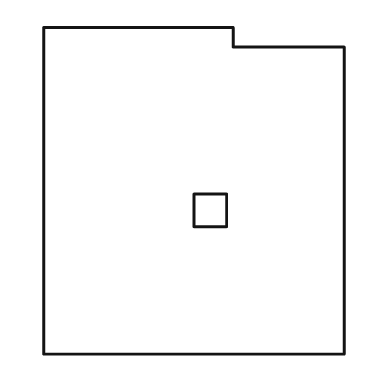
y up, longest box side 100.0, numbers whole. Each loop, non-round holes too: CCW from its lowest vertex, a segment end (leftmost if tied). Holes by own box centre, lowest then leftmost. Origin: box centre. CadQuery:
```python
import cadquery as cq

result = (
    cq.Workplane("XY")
    .moveTo(-46.0, -50.0)
    .lineTo(46.0, -50.0)
    .lineTo(46.0, 44.0)
    .lineTo(12.0, 44.0)
    .lineTo(12.0, 50.0)
    .lineTo(-46.0, 50.0)
    .close()
    .moveTo(0.0, -11.0)
    .lineTo(10.0, -11.0)
    .lineTo(10.0, -1.0)
    .lineTo(0.0, -1.0)
    .close()
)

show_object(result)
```